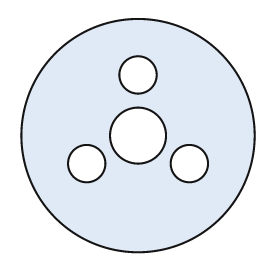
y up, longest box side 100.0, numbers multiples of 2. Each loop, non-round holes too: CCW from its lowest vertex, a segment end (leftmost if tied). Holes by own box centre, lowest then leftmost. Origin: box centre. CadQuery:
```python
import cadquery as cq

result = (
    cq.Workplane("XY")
    .moveTo(0.0, 0.0)
    .circle(50.0)
    .moveTo(-22.0, -12.0)
    .circle(8.0)
    .moveTo(22.0, -12.0)
    .circle(8.0)
    .moveTo(0.0, 0.0)
    .circle(12.0)
    .moveTo(0.0, 26.0)
    .circle(8.0)
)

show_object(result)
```